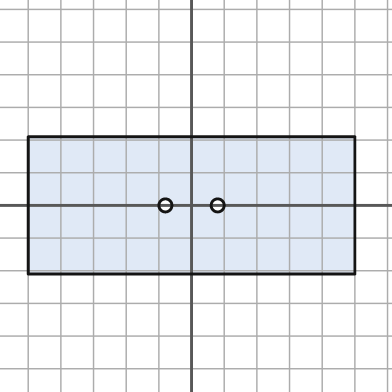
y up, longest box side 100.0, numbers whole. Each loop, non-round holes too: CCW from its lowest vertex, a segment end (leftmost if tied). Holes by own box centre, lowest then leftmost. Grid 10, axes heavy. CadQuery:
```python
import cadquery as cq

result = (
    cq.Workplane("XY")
    .moveTo(-50.0, -21.0)
    .lineTo(50.0, -21.0)
    .lineTo(50.0, 21.0)
    .lineTo(-50.0, 21.0)
    .close()
    .moveTo(-8.0, 0.0)
    .circle(2.0)
    .moveTo(8.0, 0.0)
    .circle(2.0)
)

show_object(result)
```